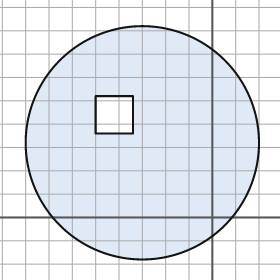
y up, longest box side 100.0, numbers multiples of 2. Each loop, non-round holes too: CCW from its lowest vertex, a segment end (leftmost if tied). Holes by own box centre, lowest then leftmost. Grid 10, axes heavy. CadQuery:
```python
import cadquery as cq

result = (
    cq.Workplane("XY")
    .moveTo(-30.0, 32.0)
    .circle(50.0)
    .moveTo(-50.0, 36.0)
    .lineTo(-34.0, 36.0)
    .lineTo(-34.0, 52.0)
    .lineTo(-50.0, 52.0)
    .close()
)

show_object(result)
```